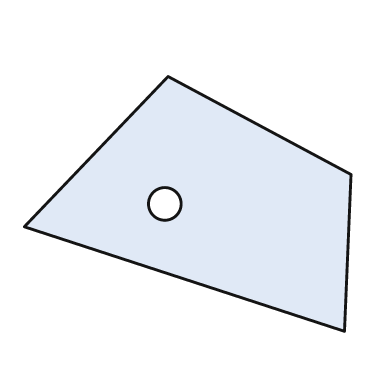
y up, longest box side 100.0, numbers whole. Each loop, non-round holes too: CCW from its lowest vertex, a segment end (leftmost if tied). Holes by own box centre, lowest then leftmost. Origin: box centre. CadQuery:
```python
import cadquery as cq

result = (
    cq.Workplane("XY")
    .moveTo(48.0, -39.0)
    .lineTo(50.0, 9.0)
    .lineTo(-6.0, 39.0)
    .lineTo(-50.0, -7.0)
    .close()
    .moveTo(-7.0, 0.0)
    .circle(5.0)
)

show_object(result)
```